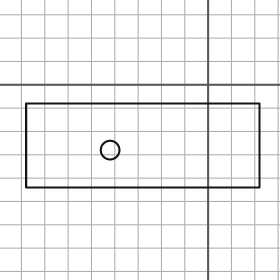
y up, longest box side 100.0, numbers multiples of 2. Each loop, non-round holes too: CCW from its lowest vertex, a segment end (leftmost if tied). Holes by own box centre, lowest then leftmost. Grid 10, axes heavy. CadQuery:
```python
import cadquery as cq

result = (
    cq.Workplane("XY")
    .moveTo(-78.0, -44.0)
    .lineTo(22.0, -44.0)
    .lineTo(22.0, -8.0)
    .lineTo(-78.0, -8.0)
    .close()
    .moveTo(-42.0, -28.0)
    .circle(4.0)
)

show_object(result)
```